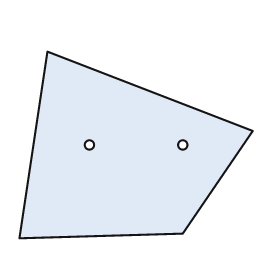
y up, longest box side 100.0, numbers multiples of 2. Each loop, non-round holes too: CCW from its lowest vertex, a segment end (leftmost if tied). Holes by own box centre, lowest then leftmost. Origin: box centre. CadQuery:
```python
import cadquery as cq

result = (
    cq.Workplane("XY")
    .moveTo(-50.0, -40.0)
    .lineTo(20.0, -38.0)
    .lineTo(50.0, 6.0)
    .lineTo(-38.0, 40.0)
    .close()
    .moveTo(-20.0, 0.0)
    .circle(2.0)
    .moveTo(20.0, 0.0)
    .circle(2.0)
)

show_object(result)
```